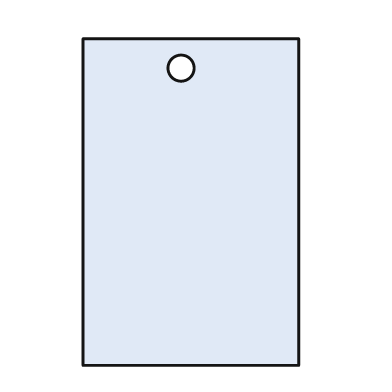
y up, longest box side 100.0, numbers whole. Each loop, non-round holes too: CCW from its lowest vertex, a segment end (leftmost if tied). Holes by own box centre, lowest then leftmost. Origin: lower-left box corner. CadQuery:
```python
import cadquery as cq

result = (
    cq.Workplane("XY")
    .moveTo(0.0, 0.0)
    .lineTo(66.0, 0.0)
    .lineTo(66.0, 100.0)
    .lineTo(0.0, 100.0)
    .close()
    .moveTo(30.0, 91.0)
    .circle(4.0)
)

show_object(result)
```